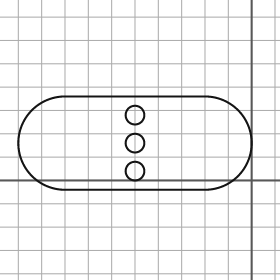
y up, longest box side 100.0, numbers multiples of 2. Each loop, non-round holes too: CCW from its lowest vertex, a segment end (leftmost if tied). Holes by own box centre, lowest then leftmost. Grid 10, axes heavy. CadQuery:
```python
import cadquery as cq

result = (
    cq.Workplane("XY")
    .moveTo(-80.0, -4.0)
    .lineTo(-20.0, -4.0)
    .threePointArc((0.0, 16.0), (-20.0, 36.0))
    .lineTo(-80.0, 36.0)
    .threePointArc((-100.0, 16.0), (-80.0, -4.0))
    .close()
    .moveTo(-50.0, 4.0)
    .circle(4.0)
    .moveTo(-50.0, 16.0)
    .circle(4.0)
    .moveTo(-50.0, 28.0)
    .circle(4.0)
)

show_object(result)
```